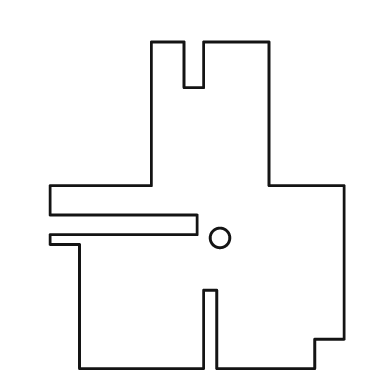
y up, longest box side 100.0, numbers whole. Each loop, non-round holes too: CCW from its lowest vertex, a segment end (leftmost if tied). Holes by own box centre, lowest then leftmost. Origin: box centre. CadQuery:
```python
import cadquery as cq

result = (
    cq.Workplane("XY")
    .moveTo(-36.0, -50.0)
    .lineTo(2.0, -50.0)
    .lineTo(2.0, -26.0)
    .lineTo(6.0, -26.0)
    .lineTo(6.0, -50.0)
    .lineTo(36.0, -50.0)
    .lineTo(36.0, -41.0)
    .lineTo(45.0, -41.0)
    .lineTo(45.0, 6.0)
    .lineTo(22.0, 6.0)
    .lineTo(22.0, 50.0)
    .lineTo(2.0, 50.0)
    .lineTo(2.0, 36.0)
    .lineTo(-4.0, 36.0)
    .lineTo(-4.0, 50.0)
    .lineTo(-14.0, 50.0)
    .lineTo(-14.0, 6.0)
    .lineTo(-45.0, 6.0)
    .lineTo(-45.0, -3.0)
    .lineTo(0.0, -3.0)
    .lineTo(0.0, -9.0)
    .lineTo(-45.0, -9.0)
    .lineTo(-45.0, -12.0)
    .lineTo(-36.0, -12.0)
    .close()
    .moveTo(7.0, -10.0)
    .circle(3.0)
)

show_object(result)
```